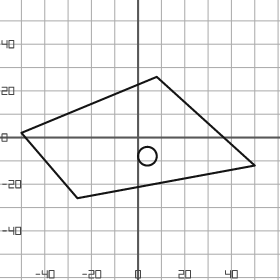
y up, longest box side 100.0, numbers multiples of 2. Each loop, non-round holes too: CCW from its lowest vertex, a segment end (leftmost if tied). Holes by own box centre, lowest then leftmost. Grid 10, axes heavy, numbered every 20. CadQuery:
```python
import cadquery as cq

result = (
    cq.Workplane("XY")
    .moveTo(-26.0, -26.0)
    .lineTo(50.0, -12.0)
    .lineTo(8.0, 26.0)
    .lineTo(-50.0, 2.0)
    .close()
    .moveTo(4.0, -8.0)
    .circle(4.0)
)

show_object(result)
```